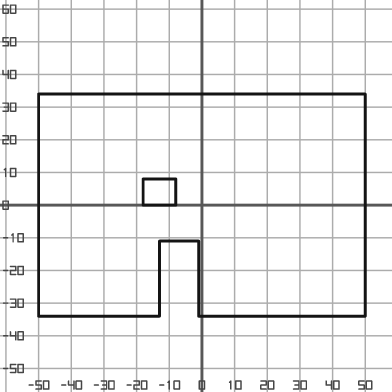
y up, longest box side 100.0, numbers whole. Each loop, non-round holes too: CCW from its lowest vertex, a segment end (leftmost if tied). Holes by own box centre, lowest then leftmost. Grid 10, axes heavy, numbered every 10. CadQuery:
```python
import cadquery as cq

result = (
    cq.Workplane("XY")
    .moveTo(-50.0, -34.0)
    .lineTo(-13.0, -34.0)
    .lineTo(-13.0, -11.0)
    .lineTo(-1.0, -11.0)
    .lineTo(-1.0, -34.0)
    .lineTo(50.0, -34.0)
    .lineTo(50.0, 34.0)
    .lineTo(-50.0, 34.0)
    .close()
    .moveTo(-18.0, 0.0)
    .lineTo(-8.0, 0.0)
    .lineTo(-8.0, 8.0)
    .lineTo(-18.0, 8.0)
    .close()
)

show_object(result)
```